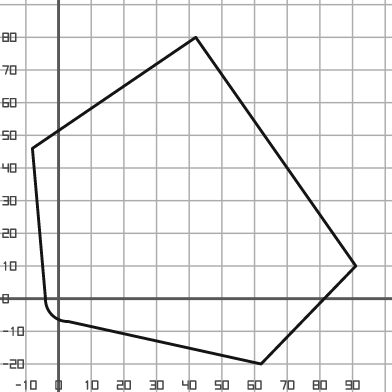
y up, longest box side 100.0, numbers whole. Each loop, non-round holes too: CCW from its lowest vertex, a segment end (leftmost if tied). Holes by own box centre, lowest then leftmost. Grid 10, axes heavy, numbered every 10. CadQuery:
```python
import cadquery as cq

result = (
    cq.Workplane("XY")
    .moveTo(62.0, -20.0)
    .lineTo(91.0, 10.0)
    .lineTo(42.0, 80.0)
    .lineTo(-8.0, 46.0)
    .lineTo(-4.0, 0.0)
    .threePointArc((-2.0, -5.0), (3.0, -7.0))
    .close()
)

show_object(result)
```